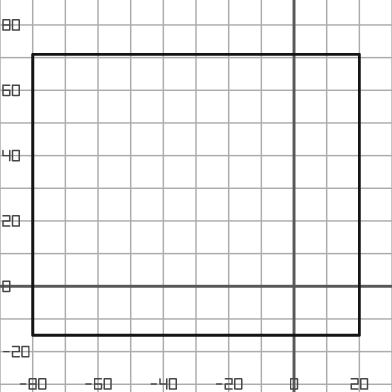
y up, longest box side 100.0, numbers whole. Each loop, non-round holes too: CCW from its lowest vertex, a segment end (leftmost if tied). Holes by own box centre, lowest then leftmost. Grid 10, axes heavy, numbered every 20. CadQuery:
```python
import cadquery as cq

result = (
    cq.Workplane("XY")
    .moveTo(-80.0, -15.0)
    .lineTo(20.0, -15.0)
    .lineTo(20.0, 71.0)
    .lineTo(-80.0, 71.0)
    .close()
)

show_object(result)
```